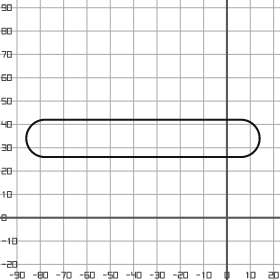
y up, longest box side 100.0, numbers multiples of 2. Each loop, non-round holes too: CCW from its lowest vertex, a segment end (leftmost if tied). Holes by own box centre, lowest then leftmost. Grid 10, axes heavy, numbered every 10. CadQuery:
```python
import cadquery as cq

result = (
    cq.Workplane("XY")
    .moveTo(-78.0, 26.0)
    .lineTo(6.0, 26.0)
    .threePointArc((14.0, 34.0), (6.0, 42.0))
    .lineTo(-78.0, 42.0)
    .threePointArc((-86.0, 34.0), (-78.0, 26.0))
    .close()
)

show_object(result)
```